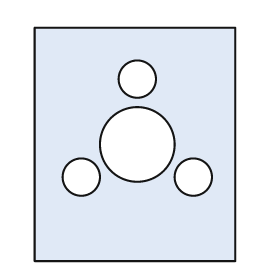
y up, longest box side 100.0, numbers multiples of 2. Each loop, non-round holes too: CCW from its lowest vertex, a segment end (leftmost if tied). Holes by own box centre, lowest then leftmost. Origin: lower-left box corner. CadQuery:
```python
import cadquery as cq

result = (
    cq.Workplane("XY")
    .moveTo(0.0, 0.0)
    .lineTo(86.0, 0.0)
    .lineTo(86.0, 100.0)
    .lineTo(0.0, 100.0)
    .close()
    .moveTo(20.0, 36.0)
    .circle(8.0)
    .moveTo(68.0, 36.0)
    .circle(8.0)
    .moveTo(44.0, 50.0)
    .circle(16.0)
    .moveTo(44.0, 78.0)
    .circle(8.0)
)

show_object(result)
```